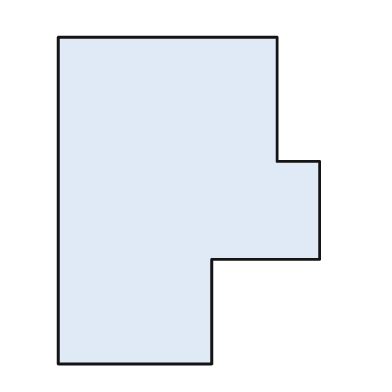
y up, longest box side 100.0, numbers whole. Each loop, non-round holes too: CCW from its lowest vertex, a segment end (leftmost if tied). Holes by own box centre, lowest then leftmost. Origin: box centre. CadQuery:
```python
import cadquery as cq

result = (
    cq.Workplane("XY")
    .moveTo(-40.0, -50.0)
    .lineTo(7.0, -50.0)
    .lineTo(7.0, -18.0)
    .lineTo(40.0, -18.0)
    .lineTo(40.0, 12.0)
    .lineTo(27.0, 12.0)
    .lineTo(27.0, 50.0)
    .lineTo(-40.0, 50.0)
    .close()
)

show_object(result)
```